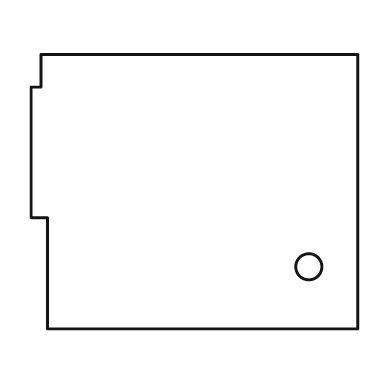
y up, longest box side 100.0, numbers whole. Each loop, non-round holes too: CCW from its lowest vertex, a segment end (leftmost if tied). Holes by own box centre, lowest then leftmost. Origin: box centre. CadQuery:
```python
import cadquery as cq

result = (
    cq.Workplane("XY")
    .moveTo(-45.0, -42.0)
    .lineTo(50.0, -42.0)
    .lineTo(50.0, 42.0)
    .lineTo(-47.0, 42.0)
    .lineTo(-47.0, 32.0)
    .lineTo(-50.0, 32.0)
    .lineTo(-50.0, -8.0)
    .lineTo(-45.0, -8.0)
    .close()
    .moveTo(35.0, -23.0)
    .circle(4.0)
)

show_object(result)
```